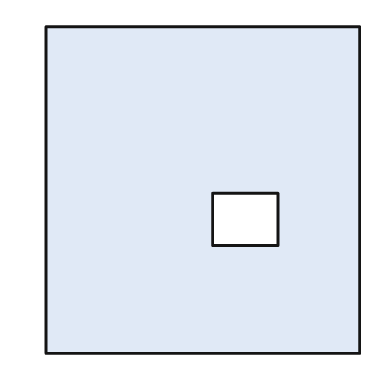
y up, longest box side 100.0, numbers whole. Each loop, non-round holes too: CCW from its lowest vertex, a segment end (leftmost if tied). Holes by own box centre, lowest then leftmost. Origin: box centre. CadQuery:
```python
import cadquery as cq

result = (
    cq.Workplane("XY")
    .moveTo(-48.0, -50.0)
    .lineTo(48.0, -50.0)
    .lineTo(48.0, 50.0)
    .lineTo(-48.0, 50.0)
    .close()
    .moveTo(3.0, -17.0)
    .lineTo(23.0, -17.0)
    .lineTo(23.0, -1.0)
    .lineTo(3.0, -1.0)
    .close()
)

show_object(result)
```